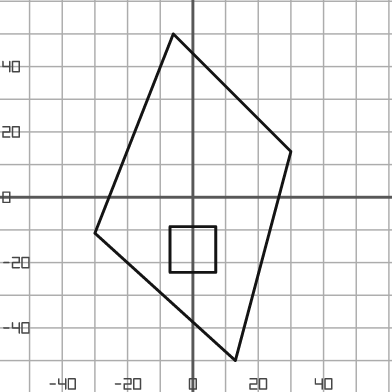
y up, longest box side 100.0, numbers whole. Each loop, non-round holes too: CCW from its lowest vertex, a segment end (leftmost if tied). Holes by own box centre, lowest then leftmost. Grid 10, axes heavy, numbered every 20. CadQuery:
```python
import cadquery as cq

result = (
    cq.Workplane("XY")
    .moveTo(13.0, -50.0)
    .lineTo(30.0, 14.0)
    .lineTo(-6.0, 50.0)
    .lineTo(-30.0, -11.0)
    .close()
    .moveTo(-7.0, -23.0)
    .lineTo(7.0, -23.0)
    .lineTo(7.0, -9.0)
    .lineTo(-7.0, -9.0)
    .close()
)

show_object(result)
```